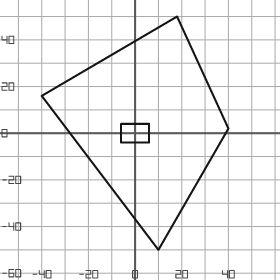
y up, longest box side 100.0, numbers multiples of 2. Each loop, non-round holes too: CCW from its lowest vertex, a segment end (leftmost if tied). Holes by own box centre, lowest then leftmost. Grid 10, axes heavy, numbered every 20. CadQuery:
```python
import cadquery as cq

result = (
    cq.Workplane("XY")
    .moveTo(10.0, -50.0)
    .lineTo(40.0, 2.0)
    .lineTo(18.0, 50.0)
    .lineTo(-40.0, 16.0)
    .close()
    .moveTo(-6.0, -4.0)
    .lineTo(6.0, -4.0)
    .lineTo(6.0, 4.0)
    .lineTo(-6.0, 4.0)
    .close()
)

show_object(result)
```